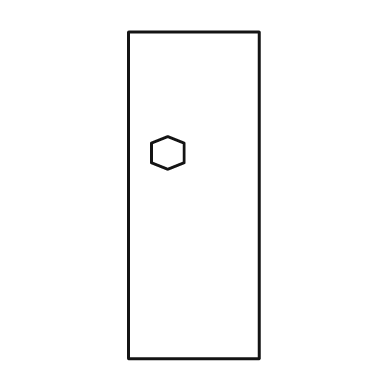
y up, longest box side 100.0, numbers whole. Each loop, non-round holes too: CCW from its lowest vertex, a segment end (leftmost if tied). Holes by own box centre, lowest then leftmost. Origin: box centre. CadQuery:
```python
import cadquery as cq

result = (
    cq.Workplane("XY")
    .moveTo(-20.0, -50.0)
    .lineTo(20.0, -50.0)
    .lineTo(20.0, 50.0)
    .lineTo(-20.0, 50.0)
    .close()
    .moveTo(-8.0, 8.0)
    .lineTo(-3.0, 10.0)
    .lineTo(-3.0, 16.0)
    .lineTo(-8.0, 18.0)
    .lineTo(-13.0, 16.0)
    .lineTo(-13.0, 10.0)
    .close()
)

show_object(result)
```